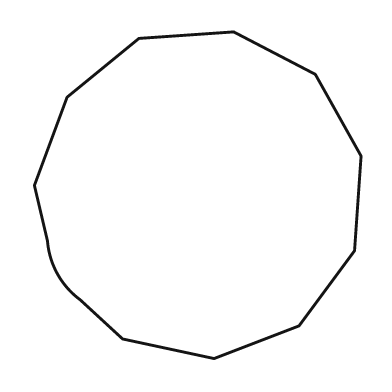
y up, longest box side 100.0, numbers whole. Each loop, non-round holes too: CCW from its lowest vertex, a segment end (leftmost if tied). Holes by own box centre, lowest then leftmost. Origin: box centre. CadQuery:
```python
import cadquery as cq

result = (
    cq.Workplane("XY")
    .moveTo(5.0, -50.0)
    .lineTo(31.0, -40.0)
    .lineTo(48.0, -17.0)
    .lineTo(50.0, 12.0)
    .lineTo(36.0, 37.0)
    .lineTo(11.0, 50.0)
    .lineTo(-18.0, 48.0)
    .lineTo(-40.0, 30.0)
    .lineTo(-50.0, 3.0)
    .lineTo(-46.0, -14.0)
    .threePointArc((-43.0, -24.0), (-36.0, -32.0))
    .lineTo(-23.0, -44.0)
    .close()
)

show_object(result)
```